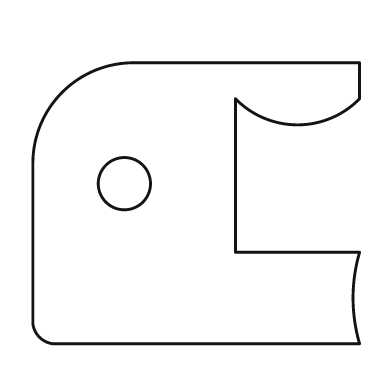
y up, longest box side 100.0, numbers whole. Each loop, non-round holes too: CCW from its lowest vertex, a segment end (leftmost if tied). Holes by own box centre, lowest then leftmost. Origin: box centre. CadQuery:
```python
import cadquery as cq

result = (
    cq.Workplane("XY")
    .moveTo(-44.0, -43.0)
    .lineTo(50.0, -43.0)
    .threePointArc((48.0, -29.0), (50.0, -15.0))
    .lineTo(12.0, -15.0)
    .lineTo(12.0, 32.0)
    .threePointArc((31.0, 24.0), (50.0, 32.0))
    .lineTo(50.0, 43.0)
    .lineTo(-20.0, 43.0)
    .threePointArc((-41.0, 34.0), (-50.0, 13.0))
    .lineTo(-50.0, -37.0)
    .threePointArc((-48.0, -41.0), (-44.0, -43.0))
    .close()
    .moveTo(-22.0, 6.0)
    .circle(8.0)
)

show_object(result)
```